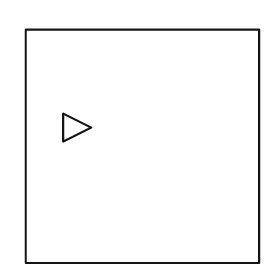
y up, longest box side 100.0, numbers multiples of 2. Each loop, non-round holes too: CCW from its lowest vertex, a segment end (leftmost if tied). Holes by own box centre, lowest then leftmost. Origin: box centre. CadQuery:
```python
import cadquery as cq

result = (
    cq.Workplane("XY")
    .moveTo(-50.0, -50.0)
    .lineTo(50.0, -50.0)
    .lineTo(50.0, 50.0)
    .lineTo(-50.0, 50.0)
    .close()
    .moveTo(-34.0, 2.0)
    .lineTo(-22.0, 8.0)
    .lineTo(-34.0, 14.0)
    .close()
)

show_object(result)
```